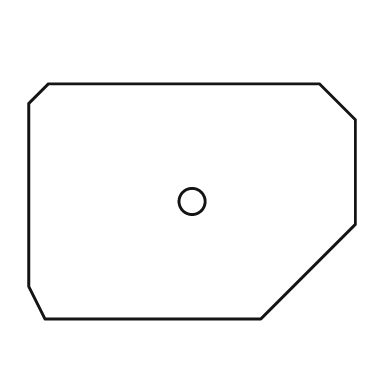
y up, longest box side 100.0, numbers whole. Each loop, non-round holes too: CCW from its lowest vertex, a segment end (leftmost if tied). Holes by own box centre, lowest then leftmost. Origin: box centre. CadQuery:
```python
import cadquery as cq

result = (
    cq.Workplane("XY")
    .moveTo(-45.0, -36.0)
    .lineTo(21.0, -36.0)
    .lineTo(50.0, -7.0)
    .lineTo(50.0, 25.0)
    .lineTo(39.0, 36.0)
    .lineTo(-44.0, 36.0)
    .lineTo(-50.0, 30.0)
    .lineTo(-50.0, -26.0)
    .close()
    .moveTo(0.0, 0.0)
    .circle(4.0)
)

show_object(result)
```